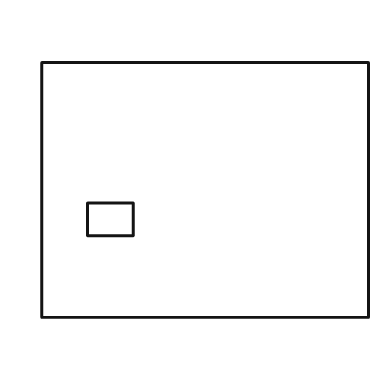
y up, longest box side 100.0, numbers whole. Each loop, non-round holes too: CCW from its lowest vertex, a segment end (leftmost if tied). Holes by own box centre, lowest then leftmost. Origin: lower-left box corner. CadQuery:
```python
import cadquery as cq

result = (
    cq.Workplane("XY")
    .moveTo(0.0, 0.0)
    .lineTo(100.0, 0.0)
    .lineTo(100.0, 78.0)
    .lineTo(0.0, 78.0)
    .close()
    .moveTo(14.0, 25.0)
    .lineTo(28.0, 25.0)
    .lineTo(28.0, 35.0)
    .lineTo(14.0, 35.0)
    .close()
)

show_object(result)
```